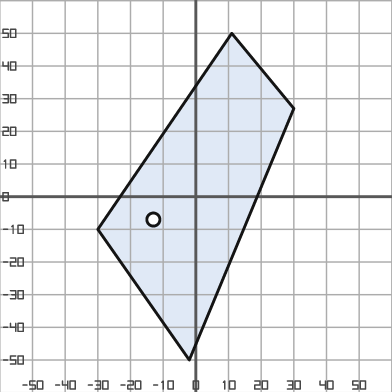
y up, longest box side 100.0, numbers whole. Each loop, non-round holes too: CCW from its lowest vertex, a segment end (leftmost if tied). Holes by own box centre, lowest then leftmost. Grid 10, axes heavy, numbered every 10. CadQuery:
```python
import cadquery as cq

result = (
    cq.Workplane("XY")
    .moveTo(-2.0, -50.0)
    .lineTo(30.0, 27.0)
    .lineTo(11.0, 50.0)
    .lineTo(-30.0, -10.0)
    .close()
    .moveTo(-13.0, -7.0)
    .circle(2.0)
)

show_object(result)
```